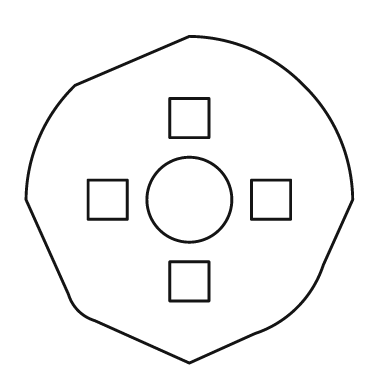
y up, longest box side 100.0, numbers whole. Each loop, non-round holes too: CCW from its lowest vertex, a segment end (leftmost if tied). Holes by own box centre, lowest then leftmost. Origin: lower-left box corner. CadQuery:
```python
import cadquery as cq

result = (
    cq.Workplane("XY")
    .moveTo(50.0, 0.0)
    .lineTo(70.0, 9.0)
    .threePointArc((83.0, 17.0), (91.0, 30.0))
    .lineTo(100.0, 50.0)
    .threePointArc((96.0, 69.0), (85.0, 85.0))
    .threePointArc((69.0, 96.0), (50.0, 100.0))
    .lineTo(15.0, 85.0)
    .threePointArc((4.0, 69.0), (0.0, 50.0))
    .lineTo(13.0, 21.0)
    .threePointArc((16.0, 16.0), (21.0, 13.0))
    .close()
    .moveTo(44.0, 19.0)
    .lineTo(56.0, 19.0)
    .lineTo(56.0, 31.0)
    .lineTo(44.0, 31.0)
    .close()
    .moveTo(19.0, 44.0)
    .lineTo(31.0, 44.0)
    .lineTo(31.0, 56.0)
    .lineTo(19.0, 56.0)
    .close()
    .moveTo(50.0, 50.0)
    .circle(13.0)
    .moveTo(69.0, 44.0)
    .lineTo(81.0, 44.0)
    .lineTo(81.0, 56.0)
    .lineTo(69.0, 56.0)
    .close()
    .moveTo(44.0, 69.0)
    .lineTo(56.0, 69.0)
    .lineTo(56.0, 81.0)
    .lineTo(44.0, 81.0)
    .close()
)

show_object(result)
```